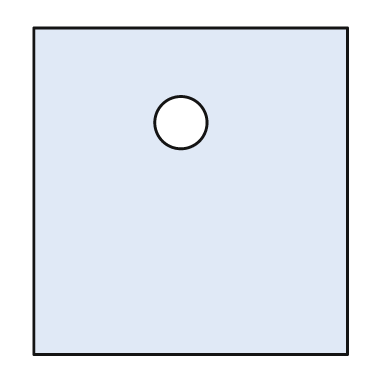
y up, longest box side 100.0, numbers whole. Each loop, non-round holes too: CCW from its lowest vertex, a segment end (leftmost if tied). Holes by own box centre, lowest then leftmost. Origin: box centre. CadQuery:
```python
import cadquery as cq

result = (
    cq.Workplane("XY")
    .moveTo(-48.0, -50.0)
    .lineTo(48.0, -50.0)
    .lineTo(48.0, 50.0)
    .lineTo(-48.0, 50.0)
    .close()
    .moveTo(-3.0, 21.0)
    .circle(8.0)
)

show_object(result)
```